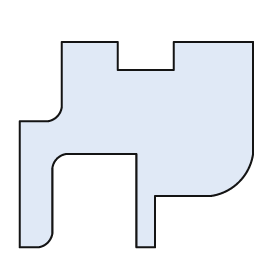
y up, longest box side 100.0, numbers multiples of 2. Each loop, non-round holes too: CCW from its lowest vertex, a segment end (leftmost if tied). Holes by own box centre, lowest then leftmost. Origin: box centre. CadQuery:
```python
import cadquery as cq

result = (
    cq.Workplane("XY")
    .moveTo(-50.0, -44.0)
    .lineTo(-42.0, -44.0)
    .threePointArc((-38.0, -42.0), (-36.0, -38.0))
    .lineTo(-36.0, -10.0)
    .threePointArc((-34.0, -6.0), (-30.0, -4.0))
    .lineTo(0.0, -4.0)
    .lineTo(0.0, -44.0)
    .lineTo(8.0, -44.0)
    .lineTo(8.0, -22.0)
    .lineTo(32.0, -22.0)
    .threePointArc((44.0, -16.0), (50.0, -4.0))
    .lineTo(50.0, 44.0)
    .lineTo(16.0, 44.0)
    .lineTo(16.0, 32.0)
    .lineTo(-8.0, 32.0)
    .lineTo(-8.0, 44.0)
    .lineTo(-32.0, 44.0)
    .lineTo(-32.0, 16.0)
    .threePointArc((-34.0, 12.0), (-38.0, 10.0))
    .lineTo(-50.0, 10.0)
    .close()
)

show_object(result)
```